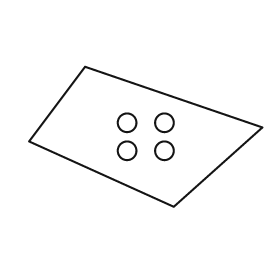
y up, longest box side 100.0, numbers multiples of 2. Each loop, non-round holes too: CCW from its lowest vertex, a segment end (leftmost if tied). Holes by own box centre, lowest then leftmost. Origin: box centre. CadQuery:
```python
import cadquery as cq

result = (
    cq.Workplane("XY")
    .moveTo(12.0, -30.0)
    .lineTo(50.0, 4.0)
    .lineTo(-26.0, 30.0)
    .lineTo(-50.0, -2.0)
    .close()
    .moveTo(-8.0, -6.0)
    .circle(4.0)
    .moveTo(8.0, -6.0)
    .circle(4.0)
    .moveTo(-8.0, 6.0)
    .circle(4.0)
    .moveTo(8.0, 6.0)
    .circle(4.0)
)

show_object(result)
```